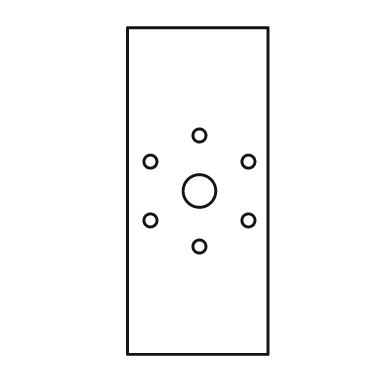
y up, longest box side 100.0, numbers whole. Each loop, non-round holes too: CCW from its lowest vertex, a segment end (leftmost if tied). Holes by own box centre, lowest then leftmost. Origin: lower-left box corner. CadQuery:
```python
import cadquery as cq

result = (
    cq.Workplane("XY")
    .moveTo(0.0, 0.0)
    .lineTo(43.0, 0.0)
    .lineTo(43.0, 100.0)
    .lineTo(0.0, 100.0)
    .close()
    .moveTo(22.0, 33.0)
    .circle(2.0)
    .moveTo(7.0, 41.0)
    .circle(2.0)
    .moveTo(37.0, 41.0)
    .circle(2.0)
    .moveTo(22.0, 50.0)
    .circle(5.0)
    .moveTo(7.0, 59.0)
    .circle(2.0)
    .moveTo(37.0, 59.0)
    .circle(2.0)
    .moveTo(22.0, 67.0)
    .circle(2.0)
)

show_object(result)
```